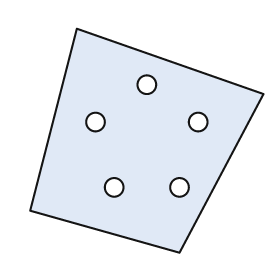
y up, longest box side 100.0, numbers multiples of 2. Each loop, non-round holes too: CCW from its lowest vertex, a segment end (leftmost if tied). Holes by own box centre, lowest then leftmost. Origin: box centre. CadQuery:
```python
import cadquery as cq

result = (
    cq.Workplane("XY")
    .moveTo(14.0, -48.0)
    .lineTo(50.0, 20.0)
    .lineTo(-30.0, 48.0)
    .lineTo(-50.0, -30.0)
    .close()
    .moveTo(-14.0, -20.0)
    .circle(4.0)
    .moveTo(14.0, -20.0)
    .circle(4.0)
    .moveTo(-22.0, 8.0)
    .circle(4.0)
    .moveTo(22.0, 8.0)
    .circle(4.0)
    .moveTo(0.0, 24.0)
    .circle(4.0)
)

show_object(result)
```